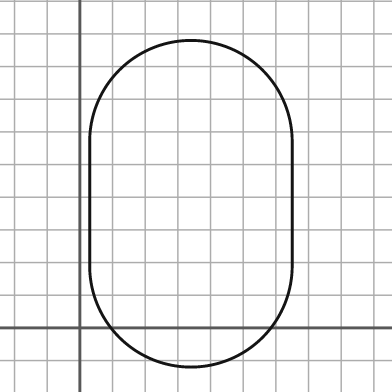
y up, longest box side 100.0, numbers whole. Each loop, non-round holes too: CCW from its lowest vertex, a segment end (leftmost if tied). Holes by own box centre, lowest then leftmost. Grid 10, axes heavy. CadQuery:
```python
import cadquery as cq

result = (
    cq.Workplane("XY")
    .moveTo(3.0, 19.0)
    .threePointArc((34.0, -12.0), (65.0, 19.0))
    .lineTo(65.0, 57.0)
    .threePointArc((34.0, 88.0), (3.0, 57.0))
    .close()
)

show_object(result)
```